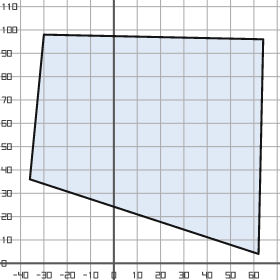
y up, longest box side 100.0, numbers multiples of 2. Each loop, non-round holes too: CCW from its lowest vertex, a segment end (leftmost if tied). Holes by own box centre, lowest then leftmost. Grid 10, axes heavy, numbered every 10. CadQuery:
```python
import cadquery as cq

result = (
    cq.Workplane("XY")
    .moveTo(62.0, 4.0)
    .lineTo(64.0, 96.0)
    .lineTo(-30.0, 98.0)
    .lineTo(-36.0, 36.0)
    .close()
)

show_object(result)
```